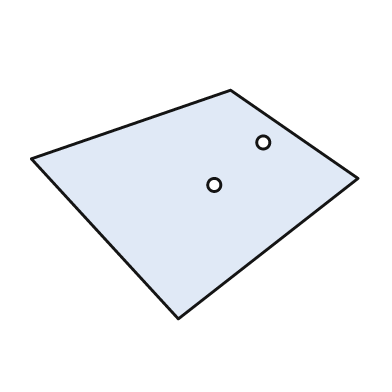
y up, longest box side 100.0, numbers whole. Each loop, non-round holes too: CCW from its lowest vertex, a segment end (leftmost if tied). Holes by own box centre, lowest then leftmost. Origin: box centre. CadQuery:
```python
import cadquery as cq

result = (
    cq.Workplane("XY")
    .moveTo(-5.0, -35.0)
    .lineTo(50.0, 8.0)
    .lineTo(11.0, 35.0)
    .lineTo(-50.0, 14.0)
    .close()
    .moveTo(6.0, 6.0)
    .circle(2.0)
    .moveTo(21.0, 19.0)
    .circle(2.0)
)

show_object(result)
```